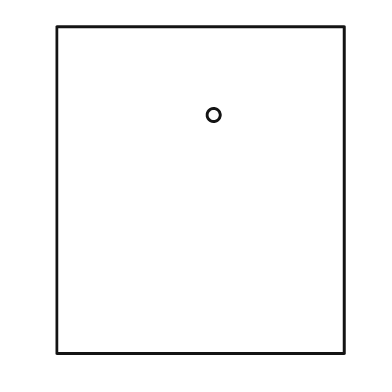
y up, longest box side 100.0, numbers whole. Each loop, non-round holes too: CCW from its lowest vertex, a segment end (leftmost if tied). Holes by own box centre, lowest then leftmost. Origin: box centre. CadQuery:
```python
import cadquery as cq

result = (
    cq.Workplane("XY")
    .moveTo(-44.0, -50.0)
    .lineTo(44.0, -50.0)
    .lineTo(44.0, 50.0)
    .lineTo(-44.0, 50.0)
    .close()
    .moveTo(4.0, 23.0)
    .circle(2.0)
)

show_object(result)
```